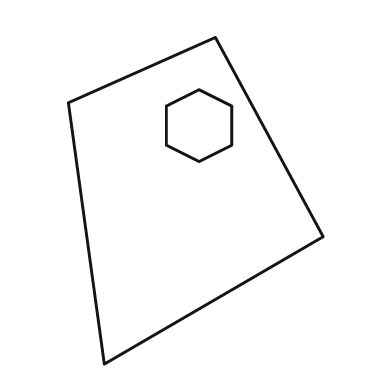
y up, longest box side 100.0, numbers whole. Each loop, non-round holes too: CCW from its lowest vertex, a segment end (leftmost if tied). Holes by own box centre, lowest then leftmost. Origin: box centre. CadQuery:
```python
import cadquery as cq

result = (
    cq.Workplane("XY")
    .moveTo(-28.0, -50.0)
    .lineTo(39.0, -11.0)
    .lineTo(6.0, 50.0)
    .lineTo(-39.0, 30.0)
    .close()
    .moveTo(1.0, 12.0)
    .lineTo(11.0, 17.0)
    .lineTo(11.0, 29.0)
    .lineTo(1.0, 34.0)
    .lineTo(-9.0, 29.0)
    .lineTo(-9.0, 17.0)
    .close()
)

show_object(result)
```